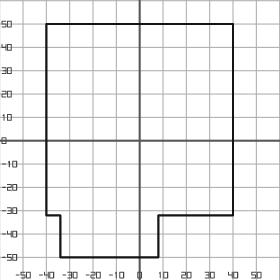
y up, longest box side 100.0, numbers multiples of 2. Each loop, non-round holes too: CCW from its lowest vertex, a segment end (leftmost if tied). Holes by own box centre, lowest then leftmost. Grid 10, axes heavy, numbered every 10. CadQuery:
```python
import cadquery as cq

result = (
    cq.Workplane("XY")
    .moveTo(-34.0, -50.0)
    .lineTo(8.0, -50.0)
    .lineTo(8.0, -32.0)
    .lineTo(40.0, -32.0)
    .lineTo(40.0, 50.0)
    .lineTo(-40.0, 50.0)
    .lineTo(-40.0, -32.0)
    .lineTo(-34.0, -32.0)
    .close()
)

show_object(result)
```